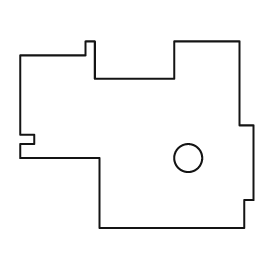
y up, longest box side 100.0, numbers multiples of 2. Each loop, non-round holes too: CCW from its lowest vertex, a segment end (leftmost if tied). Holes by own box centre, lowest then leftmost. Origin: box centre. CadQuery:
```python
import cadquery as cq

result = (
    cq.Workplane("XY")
    .moveTo(-16.0, -40.0)
    .lineTo(46.0, -40.0)
    .lineTo(46.0, -28.0)
    .lineTo(50.0, -28.0)
    .lineTo(50.0, 4.0)
    .lineTo(44.0, 4.0)
    .lineTo(44.0, 40.0)
    .lineTo(16.0, 40.0)
    .lineTo(16.0, 24.0)
    .lineTo(-18.0, 24.0)
    .lineTo(-18.0, 40.0)
    .lineTo(-22.0, 40.0)
    .lineTo(-22.0, 34.0)
    .lineTo(-50.0, 34.0)
    .lineTo(-50.0, 0.0)
    .lineTo(-44.0, 0.0)
    .lineTo(-44.0, -4.0)
    .lineTo(-50.0, -4.0)
    .lineTo(-50.0, -10.0)
    .lineTo(-16.0, -10.0)
    .close()
    .moveTo(22.0, -10.0)
    .circle(6.0)
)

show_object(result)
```